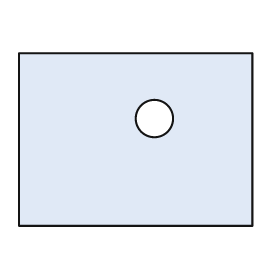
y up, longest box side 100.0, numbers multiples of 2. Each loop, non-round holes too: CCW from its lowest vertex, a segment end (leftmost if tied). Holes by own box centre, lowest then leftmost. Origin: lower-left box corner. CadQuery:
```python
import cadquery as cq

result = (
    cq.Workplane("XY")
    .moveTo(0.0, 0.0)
    .lineTo(100.0, 0.0)
    .lineTo(100.0, 74.0)
    .lineTo(0.0, 74.0)
    .close()
    .moveTo(58.0, 46.0)
    .circle(8.0)
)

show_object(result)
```